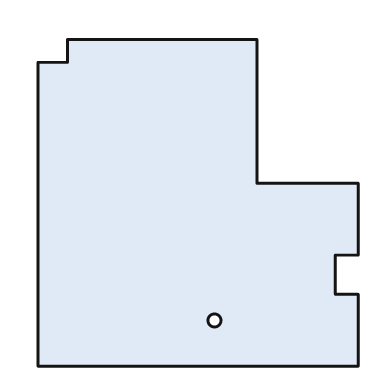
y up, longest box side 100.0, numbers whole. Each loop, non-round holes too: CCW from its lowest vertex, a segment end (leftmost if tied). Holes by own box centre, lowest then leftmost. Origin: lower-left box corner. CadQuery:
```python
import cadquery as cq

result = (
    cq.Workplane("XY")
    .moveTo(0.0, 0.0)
    .lineTo(98.0, 0.0)
    .lineTo(98.0, 22.0)
    .lineTo(91.0, 22.0)
    .lineTo(91.0, 34.0)
    .lineTo(98.0, 34.0)
    .lineTo(98.0, 56.0)
    .lineTo(67.0, 56.0)
    .lineTo(67.0, 100.0)
    .lineTo(9.0, 100.0)
    .lineTo(9.0, 93.0)
    .lineTo(0.0, 93.0)
    .close()
    .moveTo(54.0, 14.0)
    .circle(2.0)
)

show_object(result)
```